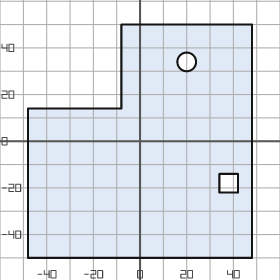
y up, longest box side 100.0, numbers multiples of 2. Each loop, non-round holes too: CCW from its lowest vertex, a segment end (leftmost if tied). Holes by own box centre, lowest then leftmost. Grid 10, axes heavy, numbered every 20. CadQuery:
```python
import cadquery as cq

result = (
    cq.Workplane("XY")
    .moveTo(-48.0, -50.0)
    .lineTo(48.0, -50.0)
    .lineTo(48.0, 50.0)
    .lineTo(-8.0, 50.0)
    .lineTo(-8.0, 14.0)
    .lineTo(-48.0, 14.0)
    .close()
    .moveTo(34.0, -22.0)
    .lineTo(42.0, -22.0)
    .lineTo(42.0, -14.0)
    .lineTo(34.0, -14.0)
    .close()
    .moveTo(20.0, 34.0)
    .circle(4.0)
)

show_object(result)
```